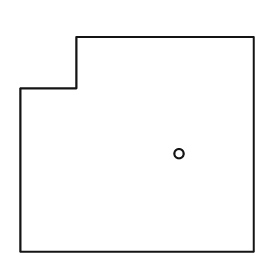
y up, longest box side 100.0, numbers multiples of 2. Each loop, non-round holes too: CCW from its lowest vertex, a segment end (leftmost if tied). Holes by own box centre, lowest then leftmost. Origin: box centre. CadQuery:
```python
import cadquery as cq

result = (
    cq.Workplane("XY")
    .moveTo(-50.0, -46.0)
    .lineTo(50.0, -46.0)
    .lineTo(50.0, 46.0)
    .lineTo(-26.0, 46.0)
    .lineTo(-26.0, 24.0)
    .lineTo(-50.0, 24.0)
    .close()
    .moveTo(18.0, -4.0)
    .circle(2.0)
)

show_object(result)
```